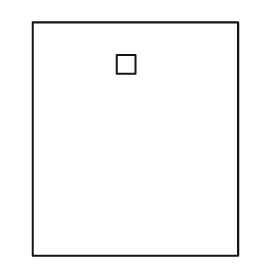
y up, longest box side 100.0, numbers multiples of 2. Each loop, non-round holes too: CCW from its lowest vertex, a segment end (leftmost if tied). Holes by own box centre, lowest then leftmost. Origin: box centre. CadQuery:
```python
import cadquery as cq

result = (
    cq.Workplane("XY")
    .moveTo(-44.0, -50.0)
    .lineTo(44.0, -50.0)
    .lineTo(44.0, 50.0)
    .lineTo(-44.0, 50.0)
    .close()
    .moveTo(-8.0, 28.0)
    .lineTo(0.0, 28.0)
    .lineTo(0.0, 36.0)
    .lineTo(-8.0, 36.0)
    .close()
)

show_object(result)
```